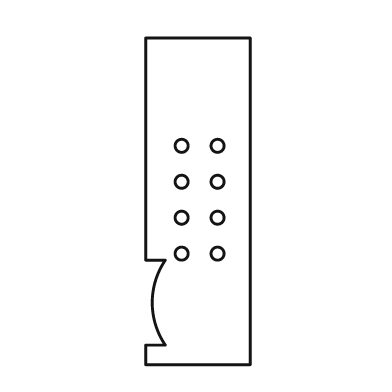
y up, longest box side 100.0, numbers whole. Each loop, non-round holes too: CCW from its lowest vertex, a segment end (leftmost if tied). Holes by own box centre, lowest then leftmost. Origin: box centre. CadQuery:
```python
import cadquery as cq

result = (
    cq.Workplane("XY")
    .moveTo(-16.0, -50.0)
    .lineTo(16.0, -50.0)
    .lineTo(16.0, 50.0)
    .lineTo(-16.0, 50.0)
    .lineTo(-16.0, -18.0)
    .lineTo(-10.0, -18.0)
    .threePointArc((-14.0, -31.0), (-10.0, -44.0))
    .lineTo(-16.0, -44.0)
    .close()
    .moveTo(-5.0, -16.0)
    .circle(2.0)
    .moveTo(6.0, -16.0)
    .circle(2.0)
    .moveTo(-5.0, -5.0)
    .circle(2.0)
    .moveTo(6.0, -5.0)
    .circle(2.0)
    .moveTo(-5.0, 6.0)
    .circle(2.0)
    .moveTo(6.0, 6.0)
    .circle(2.0)
    .moveTo(-5.0, 17.0)
    .circle(2.0)
    .moveTo(6.0, 17.0)
    .circle(2.0)
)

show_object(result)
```